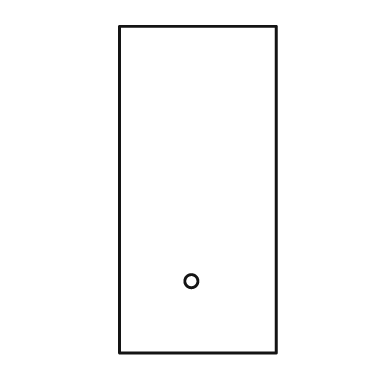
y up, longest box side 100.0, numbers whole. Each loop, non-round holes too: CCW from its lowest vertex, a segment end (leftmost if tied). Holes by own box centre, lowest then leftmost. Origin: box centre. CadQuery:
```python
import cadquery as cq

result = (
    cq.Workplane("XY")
    .moveTo(-24.0, -50.0)
    .lineTo(24.0, -50.0)
    .lineTo(24.0, 50.0)
    .lineTo(-24.0, 50.0)
    .close()
    .moveTo(-2.0, -28.0)
    .circle(2.0)
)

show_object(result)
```